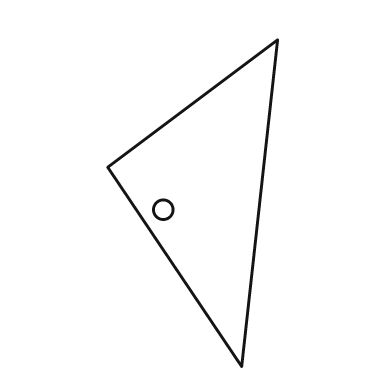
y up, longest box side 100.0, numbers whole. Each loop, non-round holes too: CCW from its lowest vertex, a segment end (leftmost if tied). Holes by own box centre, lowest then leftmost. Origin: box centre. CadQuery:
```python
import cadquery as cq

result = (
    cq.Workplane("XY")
    .moveTo(15.0, -50.0)
    .lineTo(26.0, 50.0)
    .lineTo(-26.0, 11.0)
    .close()
    .moveTo(-9.0, -2.0)
    .circle(3.0)
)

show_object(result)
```